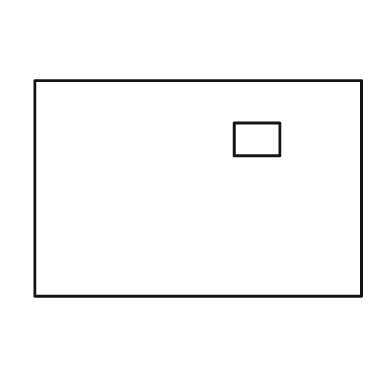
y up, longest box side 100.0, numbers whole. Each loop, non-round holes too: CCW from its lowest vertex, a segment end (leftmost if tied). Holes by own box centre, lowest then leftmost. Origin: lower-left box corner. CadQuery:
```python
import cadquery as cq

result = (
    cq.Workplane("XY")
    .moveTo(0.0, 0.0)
    .lineTo(100.0, 0.0)
    .lineTo(100.0, 66.0)
    .lineTo(0.0, 66.0)
    .close()
    .moveTo(61.0, 43.0)
    .lineTo(75.0, 43.0)
    .lineTo(75.0, 53.0)
    .lineTo(61.0, 53.0)
    .close()
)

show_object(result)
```